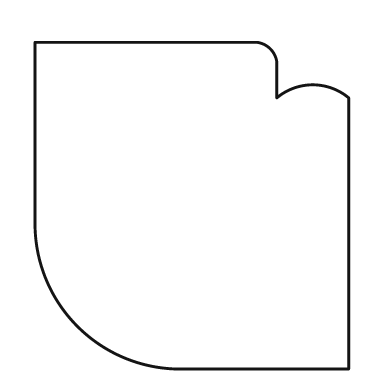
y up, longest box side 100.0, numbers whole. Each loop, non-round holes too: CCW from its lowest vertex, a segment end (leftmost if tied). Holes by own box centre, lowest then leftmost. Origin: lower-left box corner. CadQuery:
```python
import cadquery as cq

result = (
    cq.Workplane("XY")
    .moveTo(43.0, 0.0)
    .lineTo(96.0, 0.0)
    .lineTo(96.0, 83.0)
    .threePointArc((85.0, 87.0), (74.0, 83.0))
    .lineTo(74.0, 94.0)
    .threePointArc((72.0, 98.0), (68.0, 100.0))
    .lineTo(0.0, 100.0)
    .lineTo(0.0, 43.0)
    .threePointArc((13.0, 13.0), (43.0, 0.0))
    .close()
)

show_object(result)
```